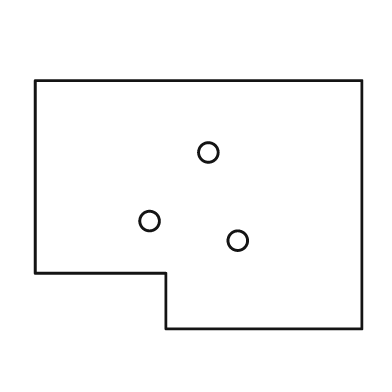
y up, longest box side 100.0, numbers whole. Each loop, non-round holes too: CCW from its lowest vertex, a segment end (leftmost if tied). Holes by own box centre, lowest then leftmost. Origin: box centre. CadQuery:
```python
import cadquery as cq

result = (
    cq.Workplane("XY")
    .moveTo(-10.0, -38.0)
    .lineTo(50.0, -38.0)
    .lineTo(50.0, 38.0)
    .lineTo(-50.0, 38.0)
    .lineTo(-50.0, -21.0)
    .lineTo(-10.0, -21.0)
    .close()
    .moveTo(12.0, -11.0)
    .circle(3.0)
    .moveTo(-15.0, -5.0)
    .circle(3.0)
    .moveTo(3.0, 16.0)
    .circle(3.0)
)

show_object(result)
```